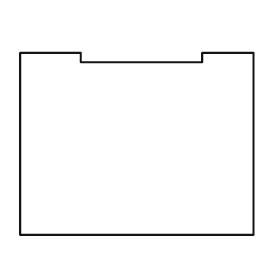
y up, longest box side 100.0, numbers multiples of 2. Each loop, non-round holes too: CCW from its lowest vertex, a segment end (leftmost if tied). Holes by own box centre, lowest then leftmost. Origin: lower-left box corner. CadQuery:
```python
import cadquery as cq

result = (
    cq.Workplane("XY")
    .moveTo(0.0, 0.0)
    .lineTo(100.0, 0.0)
    .lineTo(100.0, 78.0)
    .lineTo(78.0, 78.0)
    .lineTo(78.0, 74.0)
    .lineTo(26.0, 74.0)
    .lineTo(26.0, 78.0)
    .lineTo(0.0, 78.0)
    .close()
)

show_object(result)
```